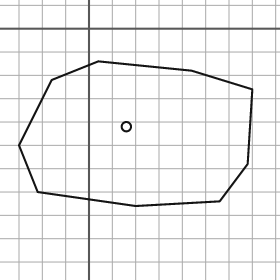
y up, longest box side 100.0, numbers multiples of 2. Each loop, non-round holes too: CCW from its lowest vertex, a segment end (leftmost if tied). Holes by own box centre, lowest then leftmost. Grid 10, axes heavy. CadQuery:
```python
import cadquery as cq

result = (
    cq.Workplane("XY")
    .moveTo(20.0, -76.0)
    .lineTo(56.0, -74.0)
    .lineTo(68.0, -58.0)
    .lineTo(70.0, -26.0)
    .lineTo(44.0, -18.0)
    .lineTo(4.0, -14.0)
    .lineTo(-16.0, -22.0)
    .lineTo(-30.0, -50.0)
    .lineTo(-22.0, -70.0)
    .close()
    .moveTo(16.0, -42.0)
    .circle(2.0)
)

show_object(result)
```